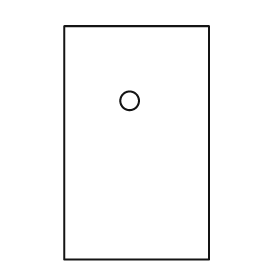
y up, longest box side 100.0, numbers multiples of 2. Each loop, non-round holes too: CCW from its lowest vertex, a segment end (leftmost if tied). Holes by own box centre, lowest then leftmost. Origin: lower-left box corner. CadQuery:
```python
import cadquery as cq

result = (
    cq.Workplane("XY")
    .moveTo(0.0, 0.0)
    .lineTo(62.0, 0.0)
    .lineTo(62.0, 100.0)
    .lineTo(0.0, 100.0)
    .close()
    .moveTo(28.0, 68.0)
    .circle(4.0)
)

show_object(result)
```